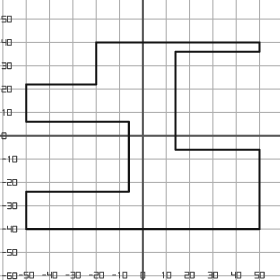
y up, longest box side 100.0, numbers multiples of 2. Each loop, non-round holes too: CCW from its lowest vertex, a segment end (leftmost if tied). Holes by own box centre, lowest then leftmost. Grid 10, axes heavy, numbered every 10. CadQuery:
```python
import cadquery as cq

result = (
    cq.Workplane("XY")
    .moveTo(-50.0, -40.0)
    .lineTo(50.0, -40.0)
    .lineTo(50.0, -6.0)
    .lineTo(14.0, -6.0)
    .lineTo(14.0, 36.0)
    .lineTo(50.0, 36.0)
    .lineTo(50.0, 40.0)
    .lineTo(-20.0, 40.0)
    .lineTo(-20.0, 22.0)
    .lineTo(-50.0, 22.0)
    .lineTo(-50.0, 6.0)
    .lineTo(-6.0, 6.0)
    .lineTo(-6.0, -24.0)
    .lineTo(-50.0, -24.0)
    .close()
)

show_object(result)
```